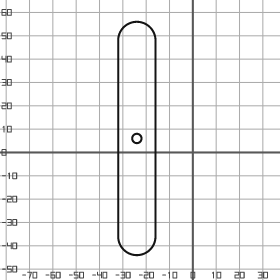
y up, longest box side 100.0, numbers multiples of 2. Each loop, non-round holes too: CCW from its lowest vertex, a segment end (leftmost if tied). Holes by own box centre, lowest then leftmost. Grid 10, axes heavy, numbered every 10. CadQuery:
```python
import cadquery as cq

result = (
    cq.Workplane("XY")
    .moveTo(-32.0, -36.0)
    .threePointArc((-24.0, -44.0), (-16.0, -36.0))
    .lineTo(-16.0, 48.0)
    .threePointArc((-24.0, 56.0), (-32.0, 48.0))
    .close()
    .moveTo(-24.0, 6.0)
    .circle(2.0)
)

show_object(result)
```